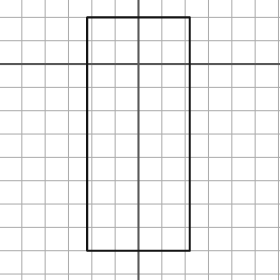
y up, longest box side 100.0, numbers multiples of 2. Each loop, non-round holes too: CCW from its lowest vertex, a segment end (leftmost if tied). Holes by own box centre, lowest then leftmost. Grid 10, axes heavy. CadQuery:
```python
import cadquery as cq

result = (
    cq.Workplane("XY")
    .moveTo(-22.0, -80.0)
    .lineTo(22.0, -80.0)
    .lineTo(22.0, 20.0)
    .lineTo(-22.0, 20.0)
    .close()
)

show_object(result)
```